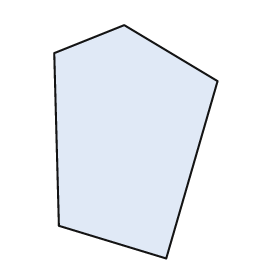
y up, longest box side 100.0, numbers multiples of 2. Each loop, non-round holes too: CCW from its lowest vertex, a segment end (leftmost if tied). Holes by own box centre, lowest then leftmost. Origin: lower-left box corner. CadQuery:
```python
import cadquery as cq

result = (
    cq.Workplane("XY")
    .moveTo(48.0, 0.0)
    .lineTo(70.0, 76.0)
    .lineTo(30.0, 100.0)
    .lineTo(0.0, 88.0)
    .lineTo(2.0, 14.0)
    .close()
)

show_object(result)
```